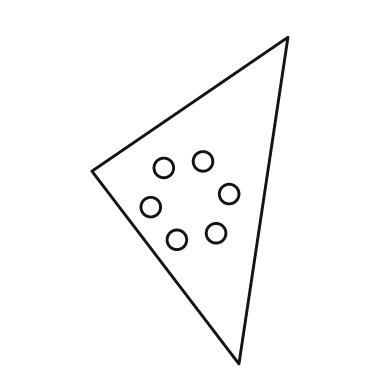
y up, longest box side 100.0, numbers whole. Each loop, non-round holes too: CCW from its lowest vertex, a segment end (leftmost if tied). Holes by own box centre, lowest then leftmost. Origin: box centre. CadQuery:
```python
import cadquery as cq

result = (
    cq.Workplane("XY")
    .moveTo(15.0, -50.0)
    .lineTo(30.0, 50.0)
    .lineTo(-30.0, 9.0)
    .close()
    .moveTo(-4.0, -12.0)
    .circle(3.0)
    .moveTo(8.0, -10.0)
    .circle(3.0)
    .moveTo(-12.0, -2.0)
    .circle(3.0)
    .moveTo(12.0, 2.0)
    .circle(3.0)
    .moveTo(-8.0, 10.0)
    .circle(3.0)
    .moveTo(4.0, 12.0)
    .circle(3.0)
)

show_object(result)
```